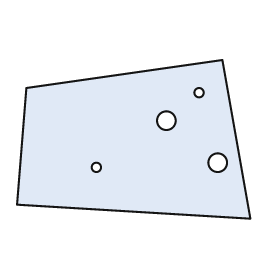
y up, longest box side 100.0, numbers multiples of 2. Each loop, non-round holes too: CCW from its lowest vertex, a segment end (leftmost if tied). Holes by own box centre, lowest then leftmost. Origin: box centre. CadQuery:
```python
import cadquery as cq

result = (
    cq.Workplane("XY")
    .moveTo(50.0, -34.0)
    .lineTo(38.0, 34.0)
    .lineTo(-46.0, 22.0)
    .lineTo(-50.0, -28.0)
    .close()
    .moveTo(-16.0, -12.0)
    .circle(2.0)
    .moveTo(36.0, -10.0)
    .circle(4.0)
    .moveTo(14.0, 8.0)
    .circle(4.0)
    .moveTo(28.0, 20.0)
    .circle(2.0)
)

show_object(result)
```